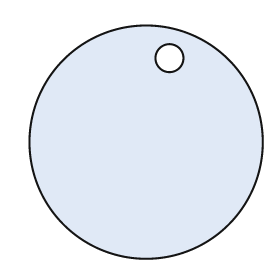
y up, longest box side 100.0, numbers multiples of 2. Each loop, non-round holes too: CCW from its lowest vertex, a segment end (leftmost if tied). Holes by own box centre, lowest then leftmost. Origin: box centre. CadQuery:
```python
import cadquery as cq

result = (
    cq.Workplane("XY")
    .moveTo(0.0, 0.0)
    .circle(50.0)
    .moveTo(10.0, 36.0)
    .circle(6.0)
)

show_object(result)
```